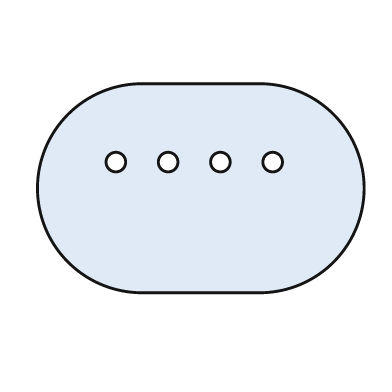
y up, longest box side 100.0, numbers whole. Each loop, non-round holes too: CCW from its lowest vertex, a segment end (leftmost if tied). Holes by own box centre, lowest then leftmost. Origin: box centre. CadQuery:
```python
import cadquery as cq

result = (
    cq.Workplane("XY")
    .moveTo(-18.0, -32.0)
    .lineTo(18.0, -32.0)
    .threePointArc((50.0, 0.0), (18.0, 32.0))
    .lineTo(-18.0, 32.0)
    .threePointArc((-50.0, 0.0), (-18.0, -32.0))
    .close()
    .moveTo(-26.0, 8.0)
    .circle(3.0)
    .moveTo(-10.0, 8.0)
    .circle(3.0)
    .moveTo(6.0, 8.0)
    .circle(3.0)
    .moveTo(22.0, 8.0)
    .circle(3.0)
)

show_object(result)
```